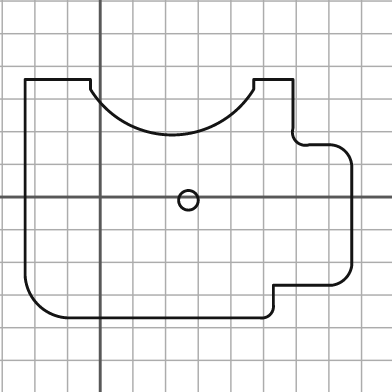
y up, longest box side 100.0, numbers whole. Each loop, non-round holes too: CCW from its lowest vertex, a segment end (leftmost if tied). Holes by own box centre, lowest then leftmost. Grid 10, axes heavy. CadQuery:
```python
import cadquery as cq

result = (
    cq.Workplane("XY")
    .moveTo(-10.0, -37.0)
    .lineTo(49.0, -37.0)
    .threePointArc((52.0, -36.0), (53.0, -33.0))
    .lineTo(53.0, -27.0)
    .lineTo(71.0, -27.0)
    .threePointArc((75.0, -25.0), (77.0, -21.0))
    .lineTo(77.0, 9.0)
    .threePointArc((75.0, 14.0), (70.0, 16.0))
    .lineTo(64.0, 16.0)
    .threePointArc((60.0, 17.0), (59.0, 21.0))
    .lineTo(59.0, 36.0)
    .lineTo(47.0, 36.0)
    .lineTo(47.0, 33.0)
    .threePointArc((22.0, 19.0), (-3.0, 33.0))
    .lineTo(-3.0, 36.0)
    .lineTo(-23.0, 36.0)
    .lineTo(-23.0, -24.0)
    .threePointArc((-19.0, -33.0), (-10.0, -37.0))
    .close()
    .moveTo(27.0, -1.0)
    .circle(3.0)
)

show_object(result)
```